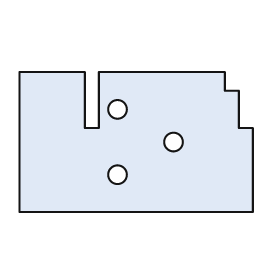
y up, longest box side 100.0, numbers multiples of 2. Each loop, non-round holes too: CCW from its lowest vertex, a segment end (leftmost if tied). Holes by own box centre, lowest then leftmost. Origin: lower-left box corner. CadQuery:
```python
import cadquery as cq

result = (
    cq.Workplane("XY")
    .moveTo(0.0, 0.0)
    .lineTo(100.0, 0.0)
    .lineTo(100.0, 36.0)
    .lineTo(94.0, 36.0)
    .lineTo(94.0, 52.0)
    .lineTo(88.0, 52.0)
    .lineTo(88.0, 60.0)
    .lineTo(34.0, 60.0)
    .lineTo(34.0, 36.0)
    .lineTo(28.0, 36.0)
    .lineTo(28.0, 60.0)
    .lineTo(0.0, 60.0)
    .close()
    .moveTo(42.0, 16.0)
    .circle(4.0)
    .moveTo(66.0, 30.0)
    .circle(4.0)
    .moveTo(42.0, 44.0)
    .circle(4.0)
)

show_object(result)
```